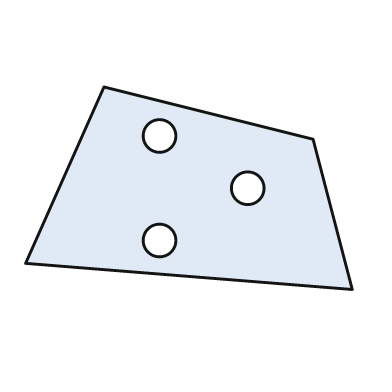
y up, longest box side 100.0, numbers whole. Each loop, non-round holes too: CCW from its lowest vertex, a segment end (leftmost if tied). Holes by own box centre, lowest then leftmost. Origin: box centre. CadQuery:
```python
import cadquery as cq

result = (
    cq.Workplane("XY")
    .moveTo(50.0, -31.0)
    .lineTo(38.0, 15.0)
    .lineTo(-26.0, 31.0)
    .lineTo(-50.0, -23.0)
    .close()
    .moveTo(-9.0, -16.0)
    .circle(5.0)
    .moveTo(18.0, 0.0)
    .circle(5.0)
    .moveTo(-9.0, 16.0)
    .circle(5.0)
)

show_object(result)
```